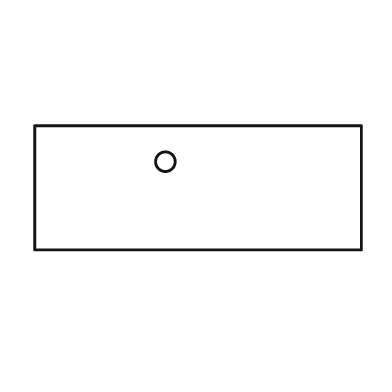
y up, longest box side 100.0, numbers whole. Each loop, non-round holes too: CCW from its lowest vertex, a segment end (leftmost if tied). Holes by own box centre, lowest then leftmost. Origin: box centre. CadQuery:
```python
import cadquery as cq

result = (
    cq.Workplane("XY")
    .moveTo(-50.0, -19.0)
    .lineTo(50.0, -19.0)
    .lineTo(50.0, 19.0)
    .lineTo(-50.0, 19.0)
    .close()
    .moveTo(-10.0, 8.0)
    .circle(3.0)
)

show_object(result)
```